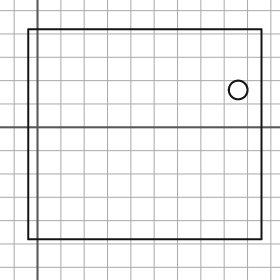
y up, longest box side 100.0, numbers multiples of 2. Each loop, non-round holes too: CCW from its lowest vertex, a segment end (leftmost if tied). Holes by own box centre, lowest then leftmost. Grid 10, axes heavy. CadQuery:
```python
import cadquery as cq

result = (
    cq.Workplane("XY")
    .moveTo(-4.0, -48.0)
    .lineTo(96.0, -48.0)
    .lineTo(96.0, 42.0)
    .lineTo(-4.0, 42.0)
    .close()
    .moveTo(86.0, 16.0)
    .circle(4.0)
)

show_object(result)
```